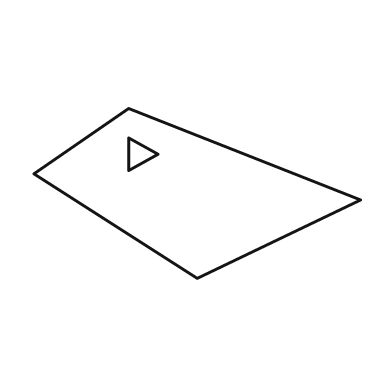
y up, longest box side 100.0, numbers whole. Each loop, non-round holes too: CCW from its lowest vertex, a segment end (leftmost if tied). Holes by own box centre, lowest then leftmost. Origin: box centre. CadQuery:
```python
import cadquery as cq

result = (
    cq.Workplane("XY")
    .moveTo(0.0, -26.0)
    .lineTo(50.0, -2.0)
    .lineTo(-21.0, 26.0)
    .lineTo(-50.0, 6.0)
    .close()
    .moveTo(-21.0, 7.0)
    .lineTo(-12.0, 12.0)
    .lineTo(-21.0, 17.0)
    .close()
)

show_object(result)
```